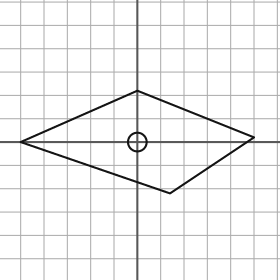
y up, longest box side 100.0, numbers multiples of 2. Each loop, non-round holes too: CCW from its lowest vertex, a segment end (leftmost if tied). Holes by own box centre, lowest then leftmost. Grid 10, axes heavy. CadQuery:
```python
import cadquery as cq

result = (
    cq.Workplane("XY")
    .moveTo(14.0, -22.0)
    .lineTo(50.0, 2.0)
    .lineTo(0.0, 22.0)
    .lineTo(-50.0, 0.0)
    .close()
    .moveTo(0.0, 0.0)
    .circle(4.0)
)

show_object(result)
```